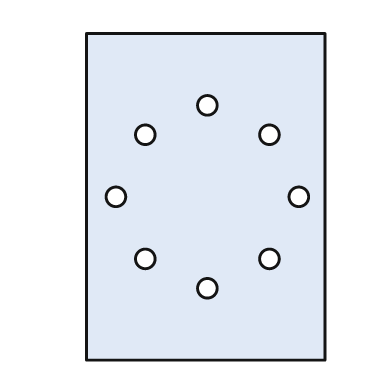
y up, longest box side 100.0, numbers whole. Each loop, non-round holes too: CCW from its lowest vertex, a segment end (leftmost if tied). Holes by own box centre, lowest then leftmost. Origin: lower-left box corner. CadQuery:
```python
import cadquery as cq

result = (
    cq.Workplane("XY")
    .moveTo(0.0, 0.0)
    .lineTo(73.0, 0.0)
    .lineTo(73.0, 100.0)
    .lineTo(0.0, 100.0)
    .close()
    .moveTo(37.0, 22.0)
    .circle(3.0)
    .moveTo(18.0, 31.0)
    .circle(3.0)
    .moveTo(56.0, 31.0)
    .circle(3.0)
    .moveTo(9.0, 50.0)
    .circle(3.0)
    .moveTo(65.0, 50.0)
    .circle(3.0)
    .moveTo(18.0, 69.0)
    .circle(3.0)
    .moveTo(56.0, 69.0)
    .circle(3.0)
    .moveTo(37.0, 78.0)
    .circle(3.0)
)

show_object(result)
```